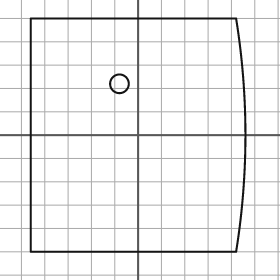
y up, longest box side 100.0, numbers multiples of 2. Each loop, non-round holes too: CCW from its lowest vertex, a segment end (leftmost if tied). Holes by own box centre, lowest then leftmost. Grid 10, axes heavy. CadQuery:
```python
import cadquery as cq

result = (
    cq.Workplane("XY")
    .moveTo(-46.0, -50.0)
    .lineTo(42.0, -50.0)
    .threePointArc((46.0, 0.0), (42.0, 50.0))
    .lineTo(-46.0, 50.0)
    .close()
    .moveTo(-8.0, 22.0)
    .circle(4.0)
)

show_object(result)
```